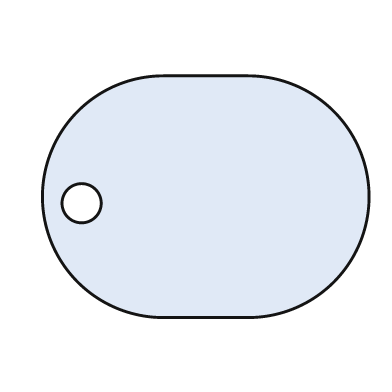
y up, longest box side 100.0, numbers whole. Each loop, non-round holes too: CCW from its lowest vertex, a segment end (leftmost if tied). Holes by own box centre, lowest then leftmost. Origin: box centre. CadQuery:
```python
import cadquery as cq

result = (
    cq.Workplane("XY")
    .moveTo(-13.0, -37.0)
    .lineTo(13.0, -37.0)
    .threePointArc((50.0, 0.0), (13.0, 37.0))
    .lineTo(-13.0, 37.0)
    .threePointArc((-50.0, 0.0), (-13.0, -37.0))
    .close()
    .moveTo(-38.0, -2.0)
    .circle(6.0)
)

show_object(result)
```